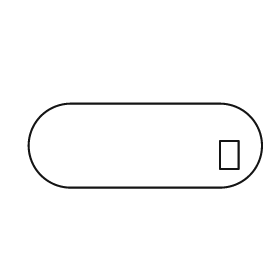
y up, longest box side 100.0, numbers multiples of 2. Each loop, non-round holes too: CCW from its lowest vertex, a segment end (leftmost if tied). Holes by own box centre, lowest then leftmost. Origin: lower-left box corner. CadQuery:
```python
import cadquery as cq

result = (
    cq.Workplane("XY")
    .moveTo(18.0, 0.0)
    .lineTo(82.0, 0.0)
    .threePointArc((100.0, 18.0), (82.0, 36.0))
    .lineTo(18.0, 36.0)
    .threePointArc((0.0, 18.0), (18.0, 0.0))
    .close()
    .moveTo(82.0, 8.0)
    .lineTo(90.0, 8.0)
    .lineTo(90.0, 20.0)
    .lineTo(82.0, 20.0)
    .close()
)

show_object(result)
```